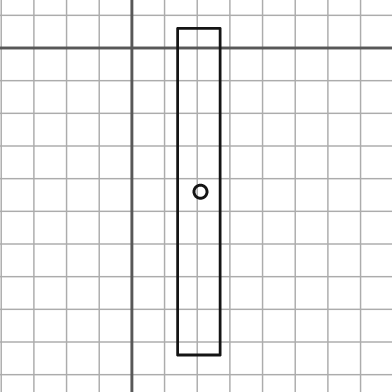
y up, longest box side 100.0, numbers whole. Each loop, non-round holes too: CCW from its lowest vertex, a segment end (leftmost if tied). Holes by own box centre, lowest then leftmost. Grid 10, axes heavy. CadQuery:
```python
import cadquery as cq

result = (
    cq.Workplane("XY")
    .moveTo(14.0, -94.0)
    .lineTo(27.0, -94.0)
    .lineTo(27.0, 6.0)
    .lineTo(14.0, 6.0)
    .close()
    .moveTo(21.0, -44.0)
    .circle(2.0)
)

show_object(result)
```